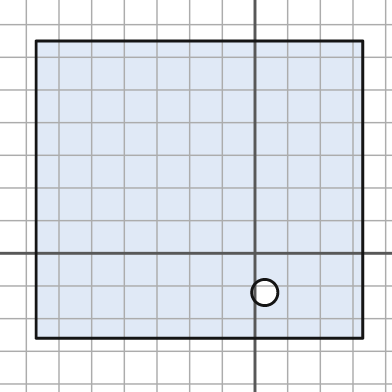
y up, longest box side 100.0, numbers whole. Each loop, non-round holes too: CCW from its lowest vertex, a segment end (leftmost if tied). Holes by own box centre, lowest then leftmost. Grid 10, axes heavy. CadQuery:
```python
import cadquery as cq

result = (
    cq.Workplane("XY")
    .moveTo(-67.0, -26.0)
    .lineTo(33.0, -26.0)
    .lineTo(33.0, 65.0)
    .lineTo(-67.0, 65.0)
    .close()
    .moveTo(3.0, -12.0)
    .circle(4.0)
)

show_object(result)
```